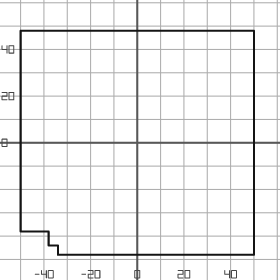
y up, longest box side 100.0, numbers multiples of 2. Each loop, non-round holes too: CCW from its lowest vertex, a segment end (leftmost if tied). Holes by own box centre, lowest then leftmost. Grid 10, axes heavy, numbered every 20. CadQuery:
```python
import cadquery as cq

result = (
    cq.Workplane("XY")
    .moveTo(-34.0, -48.0)
    .lineTo(50.0, -48.0)
    .lineTo(50.0, 48.0)
    .lineTo(-50.0, 48.0)
    .lineTo(-50.0, -38.0)
    .lineTo(-38.0, -38.0)
    .lineTo(-38.0, -44.0)
    .lineTo(-34.0, -44.0)
    .close()
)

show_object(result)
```